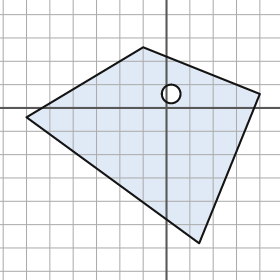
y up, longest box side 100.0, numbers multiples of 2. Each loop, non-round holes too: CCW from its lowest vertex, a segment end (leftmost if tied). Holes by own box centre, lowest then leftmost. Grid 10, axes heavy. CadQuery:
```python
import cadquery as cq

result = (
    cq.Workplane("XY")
    .moveTo(14.0, -58.0)
    .lineTo(40.0, 6.0)
    .lineTo(-10.0, 26.0)
    .lineTo(-60.0, -4.0)
    .close()
    .moveTo(2.0, 6.0)
    .circle(4.0)
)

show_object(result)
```